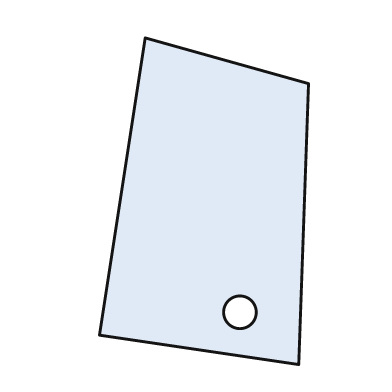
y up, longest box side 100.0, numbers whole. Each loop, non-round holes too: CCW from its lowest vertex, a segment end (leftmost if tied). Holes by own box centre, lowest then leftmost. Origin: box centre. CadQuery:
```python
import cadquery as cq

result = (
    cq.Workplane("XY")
    .moveTo(29.0, -50.0)
    .lineTo(32.0, 36.0)
    .lineTo(-18.0, 50.0)
    .lineTo(-32.0, -41.0)
    .close()
    .moveTo(11.0, -34.0)
    .circle(5.0)
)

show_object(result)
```